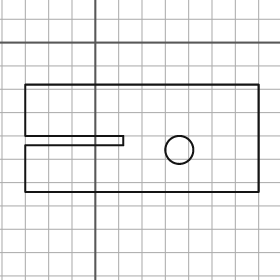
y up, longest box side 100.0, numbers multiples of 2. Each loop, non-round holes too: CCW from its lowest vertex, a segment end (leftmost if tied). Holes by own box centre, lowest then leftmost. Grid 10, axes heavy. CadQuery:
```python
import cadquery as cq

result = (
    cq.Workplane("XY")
    .moveTo(-30.0, -64.0)
    .lineTo(70.0, -64.0)
    .lineTo(70.0, -18.0)
    .lineTo(-30.0, -18.0)
    .lineTo(-30.0, -40.0)
    .lineTo(12.0, -40.0)
    .lineTo(12.0, -44.0)
    .lineTo(-30.0, -44.0)
    .close()
    .moveTo(36.0, -46.0)
    .circle(6.0)
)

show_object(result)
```